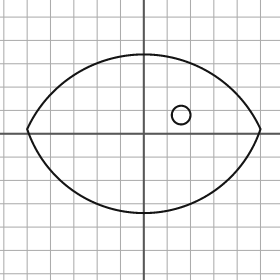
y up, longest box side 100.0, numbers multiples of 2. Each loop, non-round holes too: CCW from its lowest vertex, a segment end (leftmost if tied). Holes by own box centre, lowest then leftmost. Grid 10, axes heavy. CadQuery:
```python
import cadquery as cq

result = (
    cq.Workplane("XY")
    .moveTo(-50.0, 2.0)
    .threePointArc((0.0, -34.0), (50.0, 2.0))
    .threePointArc((0.0, 34.0), (-50.0, 2.0))
    .close()
    .moveTo(16.0, 8.0)
    .circle(4.0)
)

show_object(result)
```